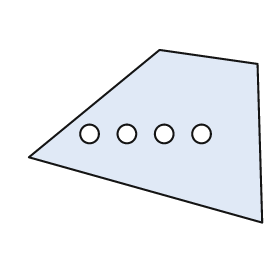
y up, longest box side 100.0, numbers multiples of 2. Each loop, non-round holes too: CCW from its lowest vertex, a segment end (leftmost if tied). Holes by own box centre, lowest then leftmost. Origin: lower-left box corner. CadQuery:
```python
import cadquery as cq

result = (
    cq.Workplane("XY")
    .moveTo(100.0, 0.0)
    .lineTo(98.0, 68.0)
    .lineTo(56.0, 74.0)
    .lineTo(0.0, 28.0)
    .close()
    .moveTo(26.0, 38.0)
    .circle(4.0)
    .moveTo(42.0, 38.0)
    .circle(4.0)
    .moveTo(58.0, 38.0)
    .circle(4.0)
    .moveTo(74.0, 38.0)
    .circle(4.0)
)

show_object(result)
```